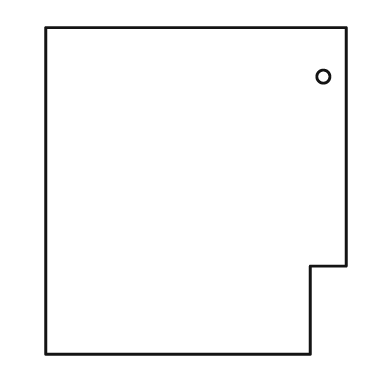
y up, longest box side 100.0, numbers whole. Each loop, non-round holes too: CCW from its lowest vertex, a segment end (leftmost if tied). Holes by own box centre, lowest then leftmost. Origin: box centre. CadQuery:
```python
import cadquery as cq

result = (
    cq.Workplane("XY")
    .moveTo(-46.0, -50.0)
    .lineTo(35.0, -50.0)
    .lineTo(35.0, -23.0)
    .lineTo(46.0, -23.0)
    .lineTo(46.0, 50.0)
    .lineTo(-46.0, 50.0)
    .close()
    .moveTo(39.0, 35.0)
    .circle(2.0)
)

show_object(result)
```